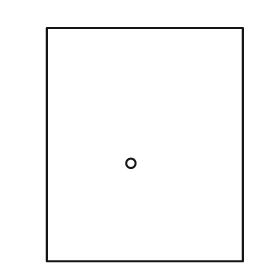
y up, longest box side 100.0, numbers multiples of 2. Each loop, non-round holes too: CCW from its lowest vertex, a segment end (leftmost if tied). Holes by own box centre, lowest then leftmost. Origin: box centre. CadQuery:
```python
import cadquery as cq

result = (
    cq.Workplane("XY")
    .moveTo(-42.0, -50.0)
    .lineTo(42.0, -50.0)
    .lineTo(42.0, 50.0)
    .lineTo(-42.0, 50.0)
    .close()
    .moveTo(-6.0, -8.0)
    .circle(2.0)
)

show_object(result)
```